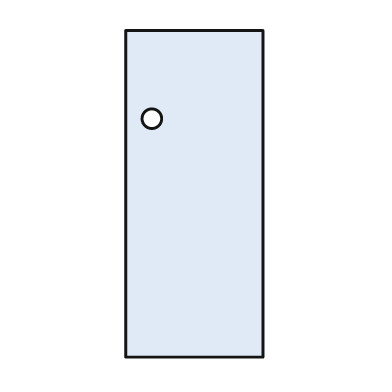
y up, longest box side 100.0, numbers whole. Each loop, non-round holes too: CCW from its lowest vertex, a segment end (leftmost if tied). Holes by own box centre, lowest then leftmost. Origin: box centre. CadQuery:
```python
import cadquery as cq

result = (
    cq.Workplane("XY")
    .moveTo(-21.0, -50.0)
    .lineTo(21.0, -50.0)
    .lineTo(21.0, 50.0)
    .lineTo(-21.0, 50.0)
    .close()
    .moveTo(-13.0, 23.0)
    .circle(3.0)
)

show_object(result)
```